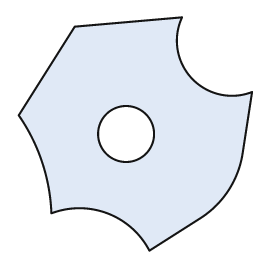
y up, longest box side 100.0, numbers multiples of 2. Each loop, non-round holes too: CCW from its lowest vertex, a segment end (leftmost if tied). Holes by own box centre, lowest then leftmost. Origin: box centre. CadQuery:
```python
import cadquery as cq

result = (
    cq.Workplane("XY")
    .moveTo(6.0, -50.0)
    .lineTo(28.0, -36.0)
    .threePointArc((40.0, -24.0), (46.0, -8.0))
    .lineTo(50.0, 18.0)
    .threePointArc((24.0, 24.0), (20.0, 50.0))
    .lineTo(-26.0, 46.0)
    .lineTo(-50.0, 8.0)
    .threePointArc((-40.0, -12.0), (-36.0, -34.0))
    .threePointArc((-12.0, -34.0), (6.0, -50.0))
    .close()
    .moveTo(-4.0, 0.0)
    .circle(12.0)
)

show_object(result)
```